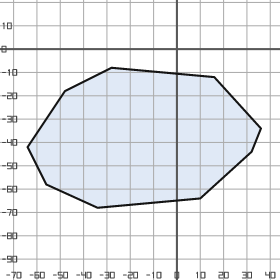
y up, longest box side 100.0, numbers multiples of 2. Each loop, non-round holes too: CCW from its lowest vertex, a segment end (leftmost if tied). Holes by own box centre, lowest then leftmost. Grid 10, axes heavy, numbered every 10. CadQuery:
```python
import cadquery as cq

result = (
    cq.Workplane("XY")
    .moveTo(-34.0, -68.0)
    .lineTo(10.0, -64.0)
    .lineTo(32.0, -44.0)
    .lineTo(36.0, -34.0)
    .lineTo(16.0, -12.0)
    .lineTo(-28.0, -8.0)
    .lineTo(-48.0, -18.0)
    .lineTo(-64.0, -42.0)
    .lineTo(-56.0, -58.0)
    .close()
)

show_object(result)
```